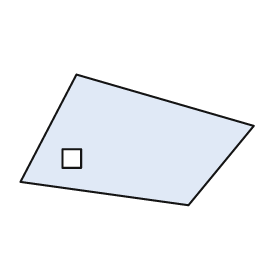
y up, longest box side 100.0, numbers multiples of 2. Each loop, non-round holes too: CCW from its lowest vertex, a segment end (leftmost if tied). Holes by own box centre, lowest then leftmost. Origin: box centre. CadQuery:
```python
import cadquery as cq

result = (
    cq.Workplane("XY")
    .moveTo(22.0, -28.0)
    .lineTo(50.0, 6.0)
    .lineTo(-26.0, 28.0)
    .lineTo(-50.0, -18.0)
    .close()
    .moveTo(-32.0, -12.0)
    .lineTo(-24.0, -12.0)
    .lineTo(-24.0, -4.0)
    .lineTo(-32.0, -4.0)
    .close()
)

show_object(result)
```